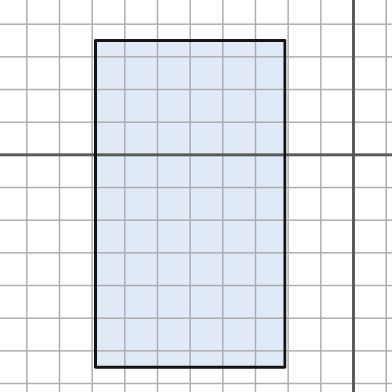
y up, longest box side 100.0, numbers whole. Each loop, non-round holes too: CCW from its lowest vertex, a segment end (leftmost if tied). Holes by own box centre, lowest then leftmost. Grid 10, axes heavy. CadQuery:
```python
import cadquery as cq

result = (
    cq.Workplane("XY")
    .moveTo(-79.0, -65.0)
    .lineTo(-21.0, -65.0)
    .lineTo(-21.0, 35.0)
    .lineTo(-79.0, 35.0)
    .close()
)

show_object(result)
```